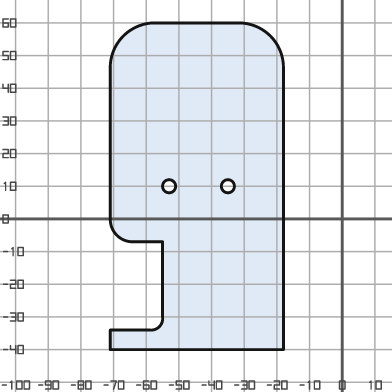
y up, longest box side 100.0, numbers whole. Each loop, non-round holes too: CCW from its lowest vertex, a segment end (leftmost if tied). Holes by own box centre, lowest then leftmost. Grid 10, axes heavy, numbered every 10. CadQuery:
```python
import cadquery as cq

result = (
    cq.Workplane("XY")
    .moveTo(-71.0, -40.0)
    .lineTo(-18.0, -40.0)
    .lineTo(-18.0, 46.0)
    .threePointArc((-22.0, 56.0), (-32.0, 60.0))
    .lineTo(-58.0, 60.0)
    .threePointArc((-67.0, 56.0), (-71.0, 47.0))
    .lineTo(-71.0, 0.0)
    .threePointArc((-69.0, -5.0), (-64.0, -7.0))
    .lineTo(-55.0, -7.0)
    .lineTo(-55.0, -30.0)
    .threePointArc((-56.0, -33.0), (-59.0, -34.0))
    .lineTo(-71.0, -34.0)
    .close()
    .moveTo(-53.0, 10.0)
    .circle(2.0)
    .moveTo(-35.0, 10.0)
    .circle(2.0)
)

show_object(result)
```